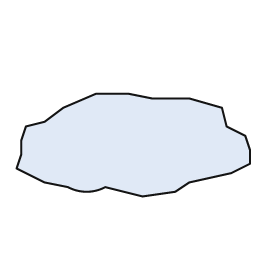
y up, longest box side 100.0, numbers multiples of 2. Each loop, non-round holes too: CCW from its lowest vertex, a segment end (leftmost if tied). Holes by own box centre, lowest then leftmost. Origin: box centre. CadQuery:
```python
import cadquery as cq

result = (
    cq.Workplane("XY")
    .moveTo(4.0, -22.0)
    .lineTo(18.0, -20.0)
    .lineTo(24.0, -16.0)
    .lineTo(42.0, -12.0)
    .lineTo(50.0, -8.0)
    .lineTo(50.0, -2.0)
    .lineTo(48.0, 4.0)
    .lineTo(40.0, 8.0)
    .lineTo(38.0, 16.0)
    .lineTo(24.0, 20.0)
    .lineTo(8.0, 20.0)
    .lineTo(-2.0, 22.0)
    .lineTo(-16.0, 22.0)
    .lineTo(-30.0, 16.0)
    .lineTo(-38.0, 10.0)
    .lineTo(-46.0, 8.0)
    .lineTo(-48.0, 2.0)
    .lineTo(-48.0, -4.0)
    .lineTo(-50.0, -10.0)
    .lineTo(-38.0, -16.0)
    .lineTo(-28.0, -18.0)
    .threePointArc((-20.0, -20.0), (-12.0, -18.0))
    .close()
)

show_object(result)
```